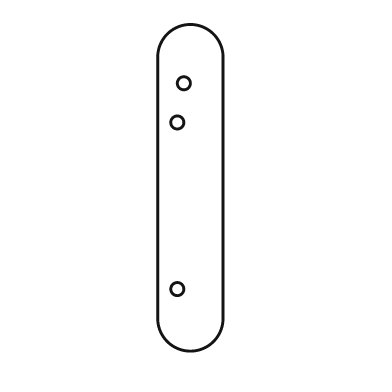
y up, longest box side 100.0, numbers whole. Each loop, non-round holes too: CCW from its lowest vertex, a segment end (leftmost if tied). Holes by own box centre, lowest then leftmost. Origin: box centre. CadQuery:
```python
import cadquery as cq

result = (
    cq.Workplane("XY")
    .moveTo(-10.0, -40.0)
    .threePointArc((0.0, -50.0), (10.0, -40.0))
    .lineTo(10.0, 40.0)
    .threePointArc((0.0, 50.0), (-10.0, 40.0))
    .close()
    .moveTo(-4.0, -31.0)
    .circle(2.0)
    .moveTo(-4.0, 20.0)
    .circle(2.0)
    .moveTo(-2.0, 32.0)
    .circle(2.0)
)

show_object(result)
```